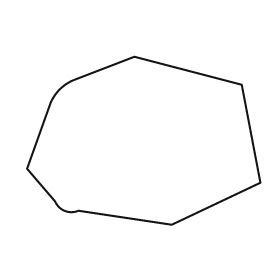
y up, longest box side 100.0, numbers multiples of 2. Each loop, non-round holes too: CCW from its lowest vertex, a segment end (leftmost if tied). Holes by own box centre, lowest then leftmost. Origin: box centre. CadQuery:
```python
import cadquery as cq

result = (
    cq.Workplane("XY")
    .moveTo(12.0, -36.0)
    .lineTo(50.0, -18.0)
    .lineTo(42.0, 24.0)
    .lineTo(-4.0, 36.0)
    .lineTo(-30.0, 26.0)
    .threePointArc((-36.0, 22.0), (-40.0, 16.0))
    .lineTo(-50.0, -12.0)
    .lineTo(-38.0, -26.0)
    .threePointArc((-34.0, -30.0), (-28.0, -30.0))
    .close()
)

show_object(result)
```